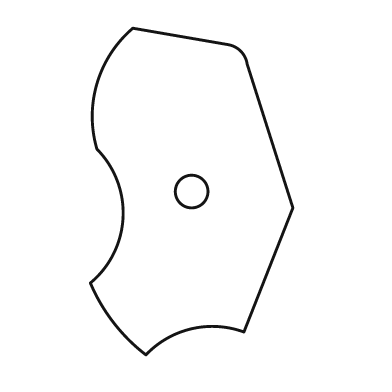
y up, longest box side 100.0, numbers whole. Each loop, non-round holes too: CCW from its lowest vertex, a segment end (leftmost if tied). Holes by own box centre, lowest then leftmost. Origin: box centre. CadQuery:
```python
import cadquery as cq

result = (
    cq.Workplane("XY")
    .moveTo(-14.0, -50.0)
    .threePointArc((0.0, -42.0), (16.0, -43.0))
    .lineTo(31.0, -5.0)
    .lineTo(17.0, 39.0)
    .threePointArc((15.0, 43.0), (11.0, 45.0))
    .lineTo(-18.0, 50.0)
    .threePointArc((-29.0, 33.0), (-29.0, 13.0))
    .threePointArc((-21.0, -8.0), (-31.0, -28.0))
    .threePointArc((-24.0, -40.0), (-14.0, -50.0))
    .close()
    .moveTo(0.0, 0.0)
    .circle(5.0)
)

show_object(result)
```